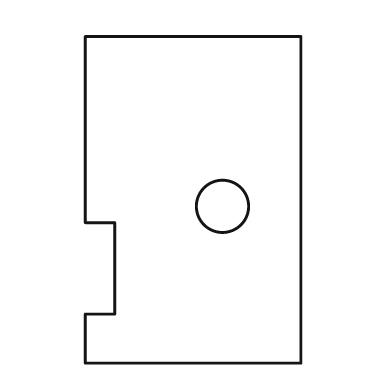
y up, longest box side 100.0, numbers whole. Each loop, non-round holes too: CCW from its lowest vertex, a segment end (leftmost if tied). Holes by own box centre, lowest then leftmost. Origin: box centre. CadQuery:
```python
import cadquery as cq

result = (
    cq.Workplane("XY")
    .moveTo(-33.0, -50.0)
    .lineTo(33.0, -50.0)
    .lineTo(33.0, 50.0)
    .lineTo(-33.0, 50.0)
    .lineTo(-33.0, -7.0)
    .lineTo(-24.0, -7.0)
    .lineTo(-24.0, -35.0)
    .lineTo(-33.0, -35.0)
    .close()
    .moveTo(9.0, -2.0)
    .circle(8.0)
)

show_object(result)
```